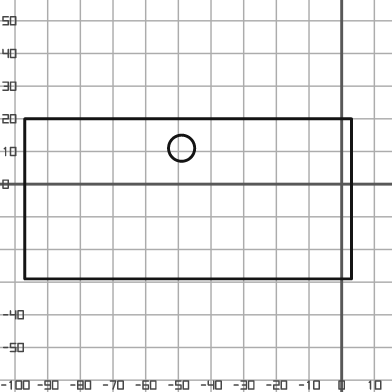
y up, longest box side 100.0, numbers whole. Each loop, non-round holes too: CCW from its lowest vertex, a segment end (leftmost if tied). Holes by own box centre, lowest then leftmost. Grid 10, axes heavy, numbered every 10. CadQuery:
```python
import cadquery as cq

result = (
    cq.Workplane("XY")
    .moveTo(-97.0, -29.0)
    .lineTo(3.0, -29.0)
    .lineTo(3.0, 20.0)
    .lineTo(-97.0, 20.0)
    .close()
    .moveTo(-49.0, 11.0)
    .circle(4.0)
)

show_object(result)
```